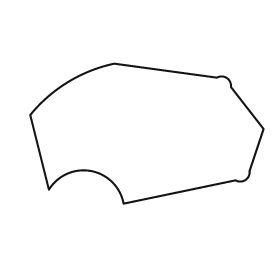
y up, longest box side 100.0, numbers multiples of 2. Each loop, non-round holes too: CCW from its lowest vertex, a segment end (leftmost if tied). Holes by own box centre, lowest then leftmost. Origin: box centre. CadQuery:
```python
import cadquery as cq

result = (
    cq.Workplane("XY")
    .moveTo(-10.0, -30.0)
    .lineTo(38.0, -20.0)
    .threePointArc((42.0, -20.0), (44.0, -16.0))
    .lineTo(50.0, 2.0)
    .lineTo(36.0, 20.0)
    .threePointArc((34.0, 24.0), (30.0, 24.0))
    .lineTo(-14.0, 30.0)
    .threePointArc((-34.0, 22.0), (-50.0, 8.0))
    .lineTo(-42.0, -24.0)
    .threePointArc((-24.0, -16.0), (-10.0, -30.0))
    .close()
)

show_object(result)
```